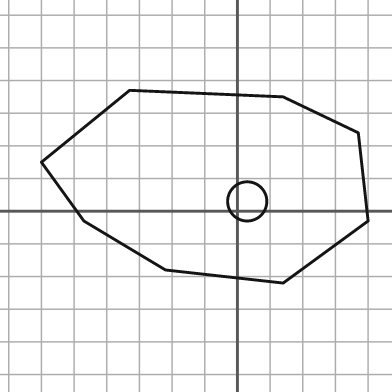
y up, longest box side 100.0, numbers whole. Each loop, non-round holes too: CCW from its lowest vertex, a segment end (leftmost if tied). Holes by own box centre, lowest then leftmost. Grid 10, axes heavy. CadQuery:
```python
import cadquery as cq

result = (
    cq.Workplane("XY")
    .moveTo(14.0, -22.0)
    .lineTo(40.0, -3.0)
    .lineTo(37.0, 24.0)
    .lineTo(14.0, 35.0)
    .lineTo(-33.0, 37.0)
    .lineTo(-60.0, 15.0)
    .lineTo(-47.0, -3.0)
    .lineTo(-22.0, -18.0)
    .close()
    .moveTo(3.0, 3.0)
    .circle(6.0)
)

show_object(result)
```